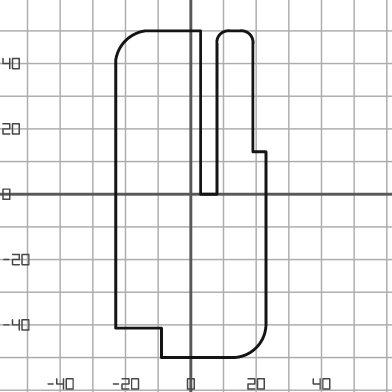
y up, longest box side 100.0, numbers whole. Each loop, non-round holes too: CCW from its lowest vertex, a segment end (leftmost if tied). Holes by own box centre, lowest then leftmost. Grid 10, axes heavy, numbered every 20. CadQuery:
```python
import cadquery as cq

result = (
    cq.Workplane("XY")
    .moveTo(-9.0, -50.0)
    .lineTo(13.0, -50.0)
    .threePointArc((20.0, -47.0), (23.0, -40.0))
    .lineTo(23.0, 13.0)
    .lineTo(19.0, 13.0)
    .lineTo(19.0, 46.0)
    .threePointArc((18.0, 49.0), (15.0, 50.0))
    .lineTo(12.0, 50.0)
    .threePointArc((9.0, 49.0), (8.0, 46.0))
    .lineTo(8.0, 0.0)
    .lineTo(3.0, 0.0)
    .lineTo(3.0, 50.0)
    .lineTo(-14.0, 50.0)
    .threePointArc((-20.0, 47.0), (-23.0, 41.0))
    .lineTo(-23.0, -41.0)
    .lineTo(-9.0, -41.0)
    .close()
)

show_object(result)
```